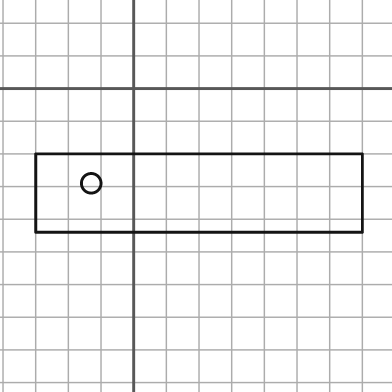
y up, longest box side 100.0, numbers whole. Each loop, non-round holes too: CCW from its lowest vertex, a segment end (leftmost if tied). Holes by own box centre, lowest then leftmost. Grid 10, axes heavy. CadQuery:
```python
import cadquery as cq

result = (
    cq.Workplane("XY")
    .moveTo(-30.0, -44.0)
    .lineTo(70.0, -44.0)
    .lineTo(70.0, -20.0)
    .lineTo(-30.0, -20.0)
    .close()
    .moveTo(-13.0, -29.0)
    .circle(3.0)
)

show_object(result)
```